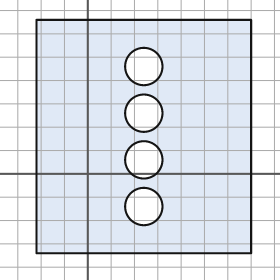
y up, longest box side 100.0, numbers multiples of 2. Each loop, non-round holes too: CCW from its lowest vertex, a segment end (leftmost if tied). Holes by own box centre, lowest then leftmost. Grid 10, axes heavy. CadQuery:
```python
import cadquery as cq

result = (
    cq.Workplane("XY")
    .moveTo(-22.0, -34.0)
    .lineTo(70.0, -34.0)
    .lineTo(70.0, 66.0)
    .lineTo(-22.0, 66.0)
    .close()
    .moveTo(24.0, -14.0)
    .circle(8.0)
    .moveTo(24.0, 6.0)
    .circle(8.0)
    .moveTo(24.0, 26.0)
    .circle(8.0)
    .moveTo(24.0, 46.0)
    .circle(8.0)
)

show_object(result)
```